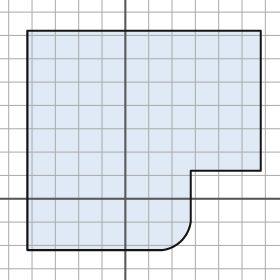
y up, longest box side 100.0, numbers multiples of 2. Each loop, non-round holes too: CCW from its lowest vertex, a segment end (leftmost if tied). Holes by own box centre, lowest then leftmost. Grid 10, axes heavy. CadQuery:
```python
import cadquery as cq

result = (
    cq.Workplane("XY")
    .moveTo(-42.0, -22.0)
    .lineTo(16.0, -22.0)
    .threePointArc((24.0, -18.0), (28.0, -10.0))
    .lineTo(28.0, 12.0)
    .lineTo(58.0, 12.0)
    .lineTo(58.0, 72.0)
    .lineTo(-42.0, 72.0)
    .close()
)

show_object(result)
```